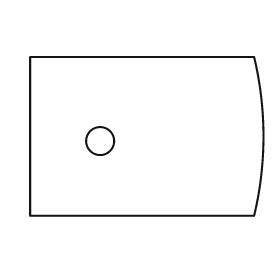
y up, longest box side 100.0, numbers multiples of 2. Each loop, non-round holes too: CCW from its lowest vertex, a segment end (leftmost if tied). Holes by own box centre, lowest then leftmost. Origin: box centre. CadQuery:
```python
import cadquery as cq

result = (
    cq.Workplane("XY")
    .moveTo(-50.0, -34.0)
    .lineTo(46.0, -34.0)
    .threePointArc((50.0, 0.0), (46.0, 34.0))
    .lineTo(-50.0, 34.0)
    .close()
    .moveTo(-20.0, -2.0)
    .circle(6.0)
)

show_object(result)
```